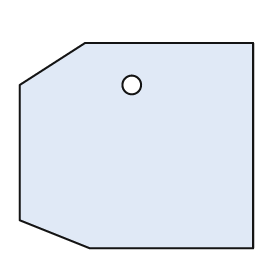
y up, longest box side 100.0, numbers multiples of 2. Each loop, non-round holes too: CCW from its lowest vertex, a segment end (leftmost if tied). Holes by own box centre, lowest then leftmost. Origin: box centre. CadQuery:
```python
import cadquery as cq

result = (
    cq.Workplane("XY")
    .moveTo(-20.0, -44.0)
    .lineTo(50.0, -44.0)
    .lineTo(50.0, 44.0)
    .lineTo(-22.0, 44.0)
    .lineTo(-50.0, 26.0)
    .lineTo(-50.0, -32.0)
    .close()
    .moveTo(-2.0, 26.0)
    .circle(4.0)
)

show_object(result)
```